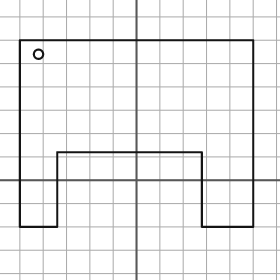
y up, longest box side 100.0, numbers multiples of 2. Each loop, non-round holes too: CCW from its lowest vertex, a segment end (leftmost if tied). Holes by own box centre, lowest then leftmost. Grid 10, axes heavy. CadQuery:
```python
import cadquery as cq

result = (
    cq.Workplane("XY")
    .moveTo(-50.0, -20.0)
    .lineTo(-34.0, -20.0)
    .lineTo(-34.0, 12.0)
    .lineTo(28.0, 12.0)
    .lineTo(28.0, -20.0)
    .lineTo(50.0, -20.0)
    .lineTo(50.0, 60.0)
    .lineTo(-50.0, 60.0)
    .close()
    .moveTo(-42.0, 54.0)
    .circle(2.0)
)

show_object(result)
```